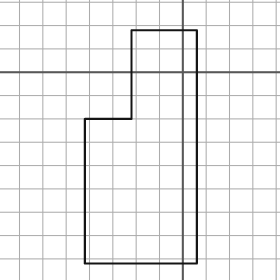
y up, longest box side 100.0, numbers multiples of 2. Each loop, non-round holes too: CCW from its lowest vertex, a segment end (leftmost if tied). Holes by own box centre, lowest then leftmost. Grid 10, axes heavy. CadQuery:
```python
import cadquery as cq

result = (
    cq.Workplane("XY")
    .moveTo(-42.0, -82.0)
    .lineTo(6.0, -82.0)
    .lineTo(6.0, 18.0)
    .lineTo(-22.0, 18.0)
    .lineTo(-22.0, -20.0)
    .lineTo(-42.0, -20.0)
    .close()
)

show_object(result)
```